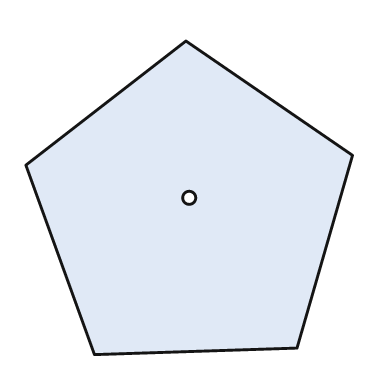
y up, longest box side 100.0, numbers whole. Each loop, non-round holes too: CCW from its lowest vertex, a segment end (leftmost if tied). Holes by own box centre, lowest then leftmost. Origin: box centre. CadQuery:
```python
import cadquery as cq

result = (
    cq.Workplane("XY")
    .moveTo(-29.0, -48.0)
    .lineTo(33.0, -46.0)
    .lineTo(50.0, 13.0)
    .lineTo(-1.0, 48.0)
    .lineTo(-50.0, 10.0)
    .close()
    .moveTo(0.0, 0.0)
    .circle(2.0)
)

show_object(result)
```